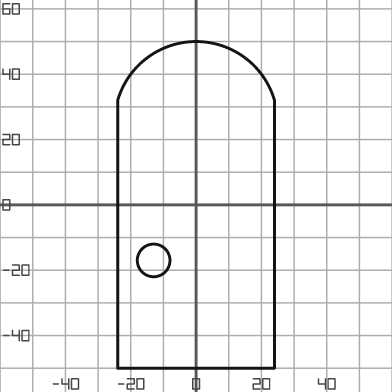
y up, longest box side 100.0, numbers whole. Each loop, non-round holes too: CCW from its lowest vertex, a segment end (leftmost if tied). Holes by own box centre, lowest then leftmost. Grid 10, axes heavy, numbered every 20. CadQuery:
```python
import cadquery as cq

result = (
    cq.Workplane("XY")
    .moveTo(-24.0, -50.0)
    .lineTo(24.0, -50.0)
    .lineTo(24.0, 32.0)
    .threePointArc((0.0, 50.0), (-24.0, 32.0))
    .close()
    .moveTo(-13.0, -17.0)
    .circle(5.0)
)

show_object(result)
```